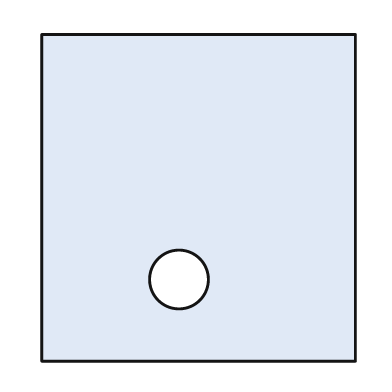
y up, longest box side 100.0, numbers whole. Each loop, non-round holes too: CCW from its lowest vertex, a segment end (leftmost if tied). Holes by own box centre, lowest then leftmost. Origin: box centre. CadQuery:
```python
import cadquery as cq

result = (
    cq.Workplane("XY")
    .moveTo(-48.0, -50.0)
    .lineTo(48.0, -50.0)
    .lineTo(48.0, 50.0)
    .lineTo(-48.0, 50.0)
    .close()
    .moveTo(-6.0, -25.0)
    .circle(9.0)
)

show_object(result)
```